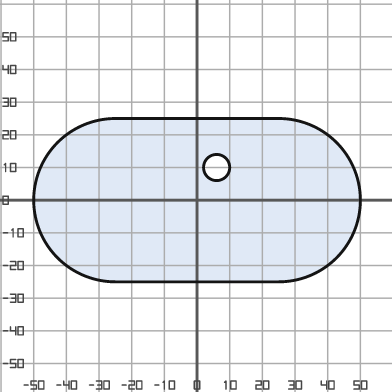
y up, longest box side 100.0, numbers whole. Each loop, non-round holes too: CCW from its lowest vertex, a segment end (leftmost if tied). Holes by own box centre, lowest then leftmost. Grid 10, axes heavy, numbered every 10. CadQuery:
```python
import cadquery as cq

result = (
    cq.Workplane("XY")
    .moveTo(-25.0, -25.0)
    .lineTo(25.0, -25.0)
    .threePointArc((50.0, 0.0), (25.0, 25.0))
    .lineTo(-25.0, 25.0)
    .threePointArc((-50.0, 0.0), (-25.0, -25.0))
    .close()
    .moveTo(6.0, 10.0)
    .circle(4.0)
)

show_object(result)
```